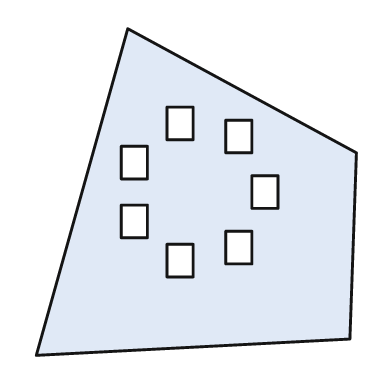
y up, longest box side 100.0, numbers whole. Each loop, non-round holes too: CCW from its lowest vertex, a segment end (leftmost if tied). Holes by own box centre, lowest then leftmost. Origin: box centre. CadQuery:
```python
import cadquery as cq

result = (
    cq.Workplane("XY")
    .moveTo(-49.0, -50.0)
    .lineTo(47.0, -45.0)
    .lineTo(49.0, 12.0)
    .lineTo(-21.0, 50.0)
    .close()
    .moveTo(-9.0, -26.0)
    .lineTo(-1.0, -26.0)
    .lineTo(-1.0, -16.0)
    .lineTo(-9.0, -16.0)
    .close()
    .moveTo(9.0, -22.0)
    .lineTo(17.0, -22.0)
    .lineTo(17.0, -12.0)
    .lineTo(9.0, -12.0)
    .close()
    .moveTo(-23.0, -14.0)
    .lineTo(-15.0, -14.0)
    .lineTo(-15.0, -4.0)
    .lineTo(-23.0, -4.0)
    .close()
    .moveTo(17.0, -5.0)
    .lineTo(25.0, -5.0)
    .lineTo(25.0, 5.0)
    .lineTo(17.0, 5.0)
    .close()
    .moveTo(-23.0, 4.0)
    .lineTo(-15.0, 4.0)
    .lineTo(-15.0, 14.0)
    .lineTo(-23.0, 14.0)
    .close()
    .moveTo(9.0, 12.0)
    .lineTo(17.0, 12.0)
    .lineTo(17.0, 22.0)
    .lineTo(9.0, 22.0)
    .close()
    .moveTo(-9.0, 16.0)
    .lineTo(-1.0, 16.0)
    .lineTo(-1.0, 26.0)
    .lineTo(-9.0, 26.0)
    .close()
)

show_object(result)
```